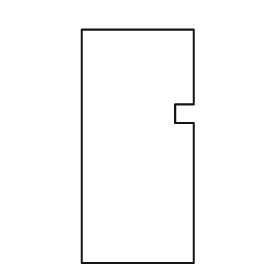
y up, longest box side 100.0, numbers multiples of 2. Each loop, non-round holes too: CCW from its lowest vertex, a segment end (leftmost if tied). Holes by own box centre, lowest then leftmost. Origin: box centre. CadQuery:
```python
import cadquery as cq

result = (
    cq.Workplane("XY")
    .moveTo(-24.0, -50.0)
    .lineTo(24.0, -50.0)
    .lineTo(24.0, 10.0)
    .lineTo(16.0, 10.0)
    .lineTo(16.0, 18.0)
    .lineTo(24.0, 18.0)
    .lineTo(24.0, 50.0)
    .lineTo(-24.0, 50.0)
    .close()
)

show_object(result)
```